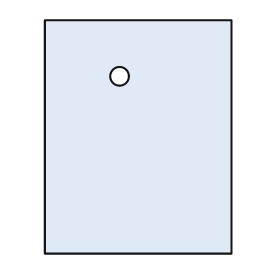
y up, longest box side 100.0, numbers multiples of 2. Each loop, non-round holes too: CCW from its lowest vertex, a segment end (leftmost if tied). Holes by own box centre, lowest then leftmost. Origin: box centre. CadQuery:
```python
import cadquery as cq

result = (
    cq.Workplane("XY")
    .moveTo(-40.0, -50.0)
    .lineTo(40.0, -50.0)
    .lineTo(40.0, 50.0)
    .lineTo(-40.0, 50.0)
    .close()
    .moveTo(-8.0, 26.0)
    .circle(4.0)
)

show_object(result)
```